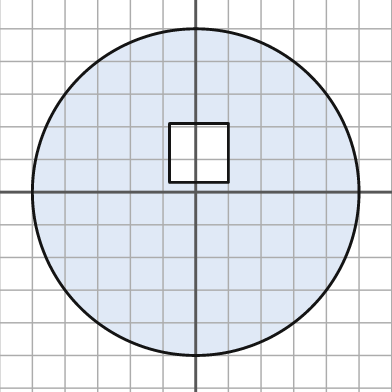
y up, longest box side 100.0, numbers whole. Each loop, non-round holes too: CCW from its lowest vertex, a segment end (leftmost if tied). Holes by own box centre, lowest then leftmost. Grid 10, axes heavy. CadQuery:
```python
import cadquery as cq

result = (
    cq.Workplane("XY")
    .moveTo(0.0, 0.0)
    .circle(50.0)
    .moveTo(-8.0, 3.0)
    .lineTo(10.0, 3.0)
    .lineTo(10.0, 21.0)
    .lineTo(-8.0, 21.0)
    .close()
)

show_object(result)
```